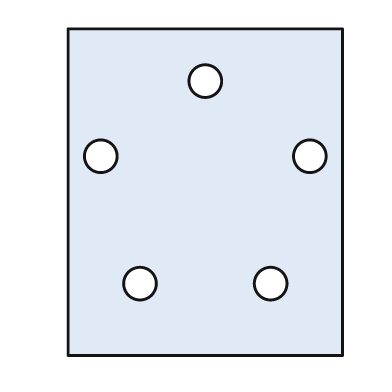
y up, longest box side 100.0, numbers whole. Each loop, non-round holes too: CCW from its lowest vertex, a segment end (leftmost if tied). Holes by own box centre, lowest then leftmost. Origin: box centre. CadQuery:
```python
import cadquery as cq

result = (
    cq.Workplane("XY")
    .moveTo(-42.0, -50.0)
    .lineTo(42.0, -50.0)
    .lineTo(42.0, 50.0)
    .lineTo(-42.0, 50.0)
    .close()
    .moveTo(-20.0, -28.0)
    .circle(5.0)
    .moveTo(20.0, -28.0)
    .circle(5.0)
    .moveTo(-32.0, 11.0)
    .circle(5.0)
    .moveTo(32.0, 11.0)
    .circle(5.0)
    .moveTo(0.0, 34.0)
    .circle(5.0)
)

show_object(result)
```